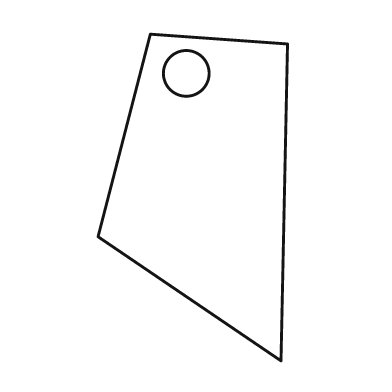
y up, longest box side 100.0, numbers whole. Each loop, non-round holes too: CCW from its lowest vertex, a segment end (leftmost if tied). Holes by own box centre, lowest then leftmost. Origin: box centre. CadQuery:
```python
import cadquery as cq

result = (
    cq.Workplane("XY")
    .moveTo(27.0, -50.0)
    .lineTo(29.0, 47.0)
    .lineTo(-13.0, 50.0)
    .lineTo(-29.0, -12.0)
    .close()
    .moveTo(-2.0, 38.0)
    .circle(7.0)
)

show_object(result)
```